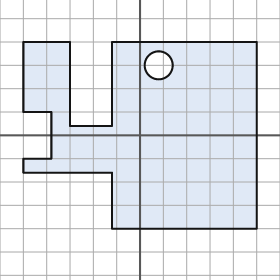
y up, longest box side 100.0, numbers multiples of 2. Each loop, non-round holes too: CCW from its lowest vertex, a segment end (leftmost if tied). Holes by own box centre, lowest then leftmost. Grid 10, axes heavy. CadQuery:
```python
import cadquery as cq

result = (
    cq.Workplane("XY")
    .moveTo(-12.0, -40.0)
    .lineTo(50.0, -40.0)
    .lineTo(50.0, 40.0)
    .lineTo(-12.0, 40.0)
    .lineTo(-12.0, 4.0)
    .lineTo(-30.0, 4.0)
    .lineTo(-30.0, 40.0)
    .lineTo(-50.0, 40.0)
    .lineTo(-50.0, 10.0)
    .lineTo(-38.0, 10.0)
    .lineTo(-38.0, -10.0)
    .lineTo(-50.0, -10.0)
    .lineTo(-50.0, -16.0)
    .lineTo(-12.0, -16.0)
    .close()
    .moveTo(8.0, 30.0)
    .circle(6.0)
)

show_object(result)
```